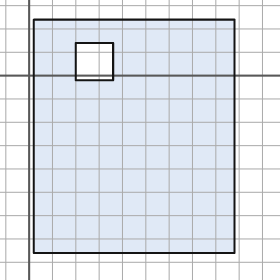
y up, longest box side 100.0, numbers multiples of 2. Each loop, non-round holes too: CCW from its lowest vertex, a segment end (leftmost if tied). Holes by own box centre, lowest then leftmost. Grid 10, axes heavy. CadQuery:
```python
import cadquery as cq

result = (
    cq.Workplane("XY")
    .moveTo(2.0, -76.0)
    .lineTo(88.0, -76.0)
    .lineTo(88.0, 24.0)
    .lineTo(2.0, 24.0)
    .close()
    .moveTo(20.0, -2.0)
    .lineTo(36.0, -2.0)
    .lineTo(36.0, 14.0)
    .lineTo(20.0, 14.0)
    .close()
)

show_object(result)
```